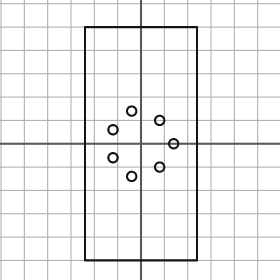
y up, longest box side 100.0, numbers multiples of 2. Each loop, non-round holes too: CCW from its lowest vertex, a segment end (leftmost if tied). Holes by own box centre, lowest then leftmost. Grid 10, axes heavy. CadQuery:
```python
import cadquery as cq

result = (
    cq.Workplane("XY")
    .moveTo(-24.0, -50.0)
    .lineTo(24.0, -50.0)
    .lineTo(24.0, 50.0)
    .lineTo(-24.0, 50.0)
    .close()
    .moveTo(-4.0, -14.0)
    .circle(2.0)
    .moveTo(8.0, -10.0)
    .circle(2.0)
    .moveTo(-12.0, -6.0)
    .circle(2.0)
    .moveTo(14.0, 0.0)
    .circle(2.0)
    .moveTo(-12.0, 6.0)
    .circle(2.0)
    .moveTo(8.0, 10.0)
    .circle(2.0)
    .moveTo(-4.0, 14.0)
    .circle(2.0)
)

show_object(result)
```